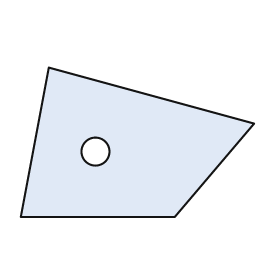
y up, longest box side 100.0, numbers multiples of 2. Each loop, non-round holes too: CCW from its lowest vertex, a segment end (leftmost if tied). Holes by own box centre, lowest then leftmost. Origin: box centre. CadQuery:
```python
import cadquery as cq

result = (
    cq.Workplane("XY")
    .moveTo(-50.0, -32.0)
    .lineTo(16.0, -32.0)
    .lineTo(50.0, 8.0)
    .lineTo(-38.0, 32.0)
    .close()
    .moveTo(-18.0, -4.0)
    .circle(6.0)
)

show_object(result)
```